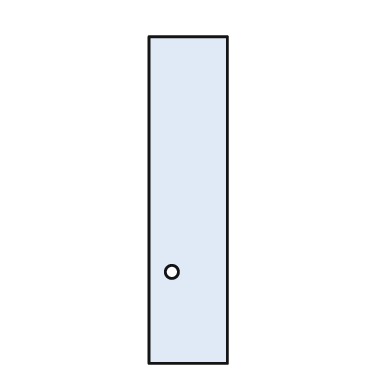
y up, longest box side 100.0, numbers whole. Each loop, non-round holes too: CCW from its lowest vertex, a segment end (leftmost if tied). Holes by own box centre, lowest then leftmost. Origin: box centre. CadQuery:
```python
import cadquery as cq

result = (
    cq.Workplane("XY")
    .moveTo(-12.0, -50.0)
    .lineTo(12.0, -50.0)
    .lineTo(12.0, 50.0)
    .lineTo(-12.0, 50.0)
    .close()
    .moveTo(-5.0, -22.0)
    .circle(2.0)
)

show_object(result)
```